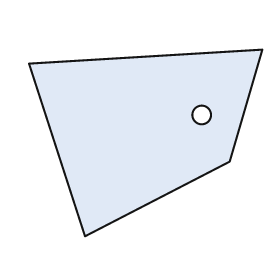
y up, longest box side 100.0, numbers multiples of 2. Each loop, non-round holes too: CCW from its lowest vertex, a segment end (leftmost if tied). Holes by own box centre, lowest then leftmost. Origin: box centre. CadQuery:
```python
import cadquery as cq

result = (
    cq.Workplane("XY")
    .moveTo(-26.0, -40.0)
    .lineTo(36.0, -8.0)
    .lineTo(50.0, 40.0)
    .lineTo(-50.0, 34.0)
    .close()
    .moveTo(24.0, 12.0)
    .circle(4.0)
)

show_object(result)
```